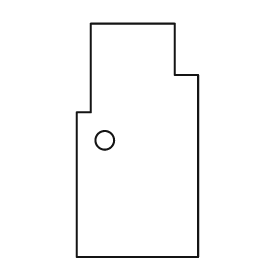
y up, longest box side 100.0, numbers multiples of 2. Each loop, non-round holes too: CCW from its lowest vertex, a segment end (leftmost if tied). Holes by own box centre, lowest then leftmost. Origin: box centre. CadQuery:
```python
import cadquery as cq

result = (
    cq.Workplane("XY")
    .moveTo(-26.0, -50.0)
    .lineTo(26.0, -50.0)
    .lineTo(26.0, 28.0)
    .lineTo(16.0, 28.0)
    .lineTo(16.0, 50.0)
    .lineTo(-20.0, 50.0)
    .lineTo(-20.0, 12.0)
    .lineTo(-26.0, 12.0)
    .close()
    .moveTo(-14.0, 0.0)
    .circle(4.0)
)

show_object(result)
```